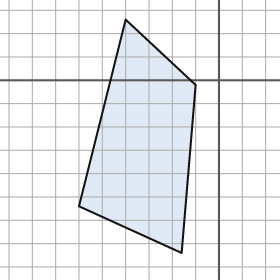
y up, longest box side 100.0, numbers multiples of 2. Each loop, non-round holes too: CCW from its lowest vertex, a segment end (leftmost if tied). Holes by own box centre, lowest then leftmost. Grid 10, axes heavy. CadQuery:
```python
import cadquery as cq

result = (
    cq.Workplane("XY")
    .moveTo(-16.0, -74.0)
    .lineTo(-10.0, -2.0)
    .lineTo(-40.0, 26.0)
    .lineTo(-60.0, -54.0)
    .close()
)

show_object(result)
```